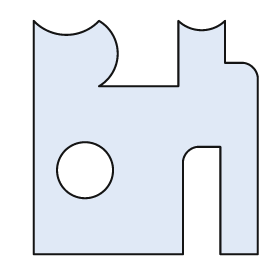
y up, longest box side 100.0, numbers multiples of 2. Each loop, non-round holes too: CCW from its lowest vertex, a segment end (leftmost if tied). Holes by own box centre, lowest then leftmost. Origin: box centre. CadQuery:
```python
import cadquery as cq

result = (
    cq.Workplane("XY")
    .moveTo(-48.0, -50.0)
    .lineTo(16.0, -50.0)
    .lineTo(16.0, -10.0)
    .threePointArc((18.0, -6.0), (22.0, -4.0))
    .lineTo(32.0, -4.0)
    .lineTo(32.0, -50.0)
    .lineTo(48.0, -50.0)
    .lineTo(48.0, 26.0)
    .threePointArc((46.0, 30.0), (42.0, 32.0))
    .lineTo(34.0, 32.0)
    .lineTo(34.0, 50.0)
    .threePointArc((24.0, 46.0), (14.0, 50.0))
    .lineTo(14.0, 22.0)
    .lineTo(-20.0, 22.0)
    .threePointArc((-12.0, 36.0), (-20.0, 50.0))
    .threePointArc((-34.0, 44.0), (-48.0, 50.0))
    .close()
    .moveTo(-26.0, -14.0)
    .circle(12.0)
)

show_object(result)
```